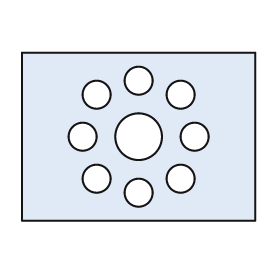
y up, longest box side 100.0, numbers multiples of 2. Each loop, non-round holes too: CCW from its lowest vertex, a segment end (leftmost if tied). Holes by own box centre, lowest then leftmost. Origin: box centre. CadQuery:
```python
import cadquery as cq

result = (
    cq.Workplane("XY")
    .moveTo(-50.0, -36.0)
    .lineTo(50.0, -36.0)
    .lineTo(50.0, 36.0)
    .lineTo(-50.0, 36.0)
    .close()
    .moveTo(0.0, -24.0)
    .circle(6.0)
    .moveTo(-18.0, -18.0)
    .circle(6.0)
    .moveTo(18.0, -18.0)
    .circle(6.0)
    .moveTo(-24.0, 0.0)
    .circle(6.0)
    .moveTo(0.0, 0.0)
    .circle(10.0)
    .moveTo(24.0, 0.0)
    .circle(6.0)
    .moveTo(-18.0, 18.0)
    .circle(6.0)
    .moveTo(18.0, 18.0)
    .circle(6.0)
    .moveTo(0.0, 24.0)
    .circle(6.0)
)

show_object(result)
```